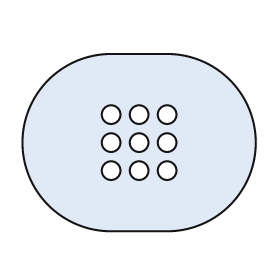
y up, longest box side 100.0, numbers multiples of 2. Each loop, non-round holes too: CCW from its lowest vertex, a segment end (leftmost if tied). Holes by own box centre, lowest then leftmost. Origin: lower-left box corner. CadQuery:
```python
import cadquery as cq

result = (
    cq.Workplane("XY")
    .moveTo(38.0, 0.0)
    .lineTo(62.0, 0.0)
    .threePointArc((100.0, 38.0), (62.0, 76.0))
    .lineTo(38.0, 76.0)
    .threePointArc((0.0, 38.0), (38.0, 0.0))
    .close()
    .moveTo(38.0, 26.0)
    .circle(4.0)
    .moveTo(50.0, 26.0)
    .circle(4.0)
    .moveTo(62.0, 26.0)
    .circle(4.0)
    .moveTo(38.0, 38.0)
    .circle(4.0)
    .moveTo(50.0, 38.0)
    .circle(4.0)
    .moveTo(62.0, 38.0)
    .circle(4.0)
    .moveTo(38.0, 50.0)
    .circle(4.0)
    .moveTo(50.0, 50.0)
    .circle(4.0)
    .moveTo(62.0, 50.0)
    .circle(4.0)
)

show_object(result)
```